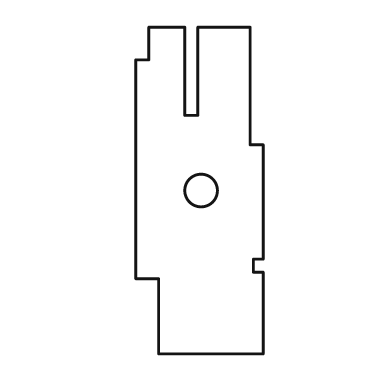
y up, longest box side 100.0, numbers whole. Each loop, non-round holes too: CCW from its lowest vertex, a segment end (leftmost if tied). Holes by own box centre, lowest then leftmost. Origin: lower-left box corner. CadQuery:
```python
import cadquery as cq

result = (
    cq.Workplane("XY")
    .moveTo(7.0, 0.0)
    .lineTo(39.0, 0.0)
    .lineTo(39.0, 25.0)
    .lineTo(36.0, 25.0)
    .lineTo(36.0, 29.0)
    .lineTo(39.0, 29.0)
    .lineTo(39.0, 64.0)
    .lineTo(35.0, 64.0)
    .lineTo(35.0, 100.0)
    .lineTo(19.0, 100.0)
    .lineTo(19.0, 73.0)
    .lineTo(15.0, 73.0)
    .lineTo(15.0, 100.0)
    .lineTo(4.0, 100.0)
    .lineTo(4.0, 90.0)
    .lineTo(0.0, 90.0)
    .lineTo(0.0, 23.0)
    .lineTo(7.0, 23.0)
    .close()
    .moveTo(20.0, 50.0)
    .circle(5.0)
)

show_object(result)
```